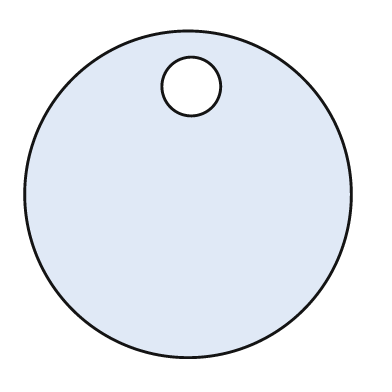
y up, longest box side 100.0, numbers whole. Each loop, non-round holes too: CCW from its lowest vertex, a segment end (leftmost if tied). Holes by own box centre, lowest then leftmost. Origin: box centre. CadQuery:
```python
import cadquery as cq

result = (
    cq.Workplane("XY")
    .moveTo(0.0, 0.0)
    .circle(50.0)
    .moveTo(1.0, 33.0)
    .circle(9.0)
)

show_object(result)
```